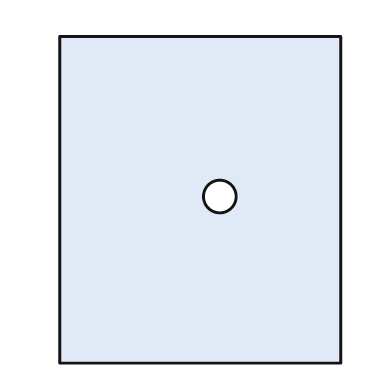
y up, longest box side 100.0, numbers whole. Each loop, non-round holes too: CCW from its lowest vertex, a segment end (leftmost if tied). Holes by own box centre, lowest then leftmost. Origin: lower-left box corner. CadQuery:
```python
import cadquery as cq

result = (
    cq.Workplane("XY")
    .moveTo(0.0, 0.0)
    .lineTo(86.0, 0.0)
    .lineTo(86.0, 100.0)
    .lineTo(0.0, 100.0)
    .close()
    .moveTo(49.0, 51.0)
    .circle(5.0)
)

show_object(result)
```